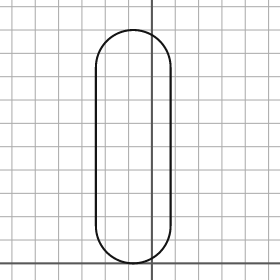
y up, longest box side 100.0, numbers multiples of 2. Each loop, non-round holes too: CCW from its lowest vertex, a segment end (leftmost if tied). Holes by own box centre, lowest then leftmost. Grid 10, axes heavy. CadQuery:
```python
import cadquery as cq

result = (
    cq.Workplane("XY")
    .moveTo(-24.0, 16.0)
    .threePointArc((-8.0, 0.0), (8.0, 16.0))
    .lineTo(8.0, 84.0)
    .threePointArc((-8.0, 100.0), (-24.0, 84.0))
    .close()
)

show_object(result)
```